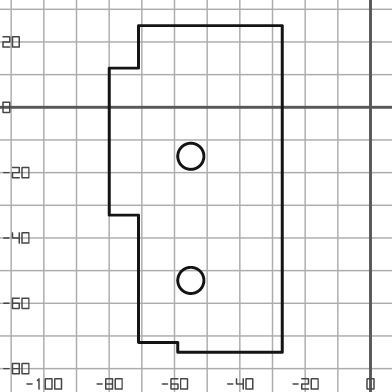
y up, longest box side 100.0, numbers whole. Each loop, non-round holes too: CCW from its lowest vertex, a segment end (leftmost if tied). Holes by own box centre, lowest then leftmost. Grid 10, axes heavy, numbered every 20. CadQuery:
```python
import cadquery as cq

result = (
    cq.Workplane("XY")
    .moveTo(-59.0, -75.0)
    .lineTo(-27.0, -75.0)
    .lineTo(-27.0, 25.0)
    .lineTo(-71.0, 25.0)
    .lineTo(-71.0, 12.0)
    .lineTo(-80.0, 12.0)
    .lineTo(-80.0, -33.0)
    .lineTo(-71.0, -33.0)
    .lineTo(-71.0, -72.0)
    .lineTo(-59.0, -72.0)
    .close()
    .moveTo(-55.0, -53.0)
    .circle(4.0)
    .moveTo(-55.0, -15.0)
    .circle(4.0)
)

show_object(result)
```